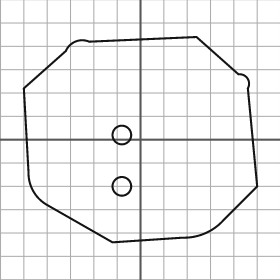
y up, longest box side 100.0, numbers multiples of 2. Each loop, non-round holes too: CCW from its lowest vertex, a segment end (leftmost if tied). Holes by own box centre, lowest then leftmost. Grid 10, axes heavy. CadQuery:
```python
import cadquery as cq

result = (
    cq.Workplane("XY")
    .moveTo(-12.0, -44.0)
    .lineTo(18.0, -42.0)
    .threePointArc((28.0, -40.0), (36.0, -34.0))
    .lineTo(50.0, -20.0)
    .lineTo(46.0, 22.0)
    .threePointArc((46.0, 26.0), (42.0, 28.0))
    .lineTo(24.0, 44.0)
    .lineTo(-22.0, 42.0)
    .threePointArc((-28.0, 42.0), (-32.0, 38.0))
    .lineTo(-50.0, 22.0)
    .lineTo(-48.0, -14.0)
    .threePointArc((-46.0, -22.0), (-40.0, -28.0))
    .close()
    .moveTo(-8.0, -20.0)
    .circle(4.0)
    .moveTo(-8.0, 2.0)
    .circle(4.0)
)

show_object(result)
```